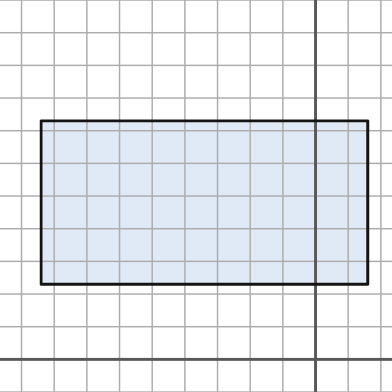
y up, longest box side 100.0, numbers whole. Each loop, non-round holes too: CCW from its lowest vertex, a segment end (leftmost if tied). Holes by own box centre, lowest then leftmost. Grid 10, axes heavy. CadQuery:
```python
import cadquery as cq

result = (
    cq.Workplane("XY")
    .moveTo(-84.0, 23.0)
    .lineTo(16.0, 23.0)
    .lineTo(16.0, 73.0)
    .lineTo(-84.0, 73.0)
    .close()
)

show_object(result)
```